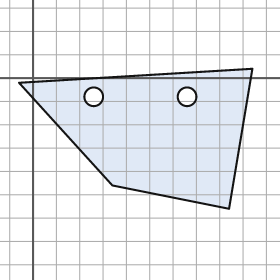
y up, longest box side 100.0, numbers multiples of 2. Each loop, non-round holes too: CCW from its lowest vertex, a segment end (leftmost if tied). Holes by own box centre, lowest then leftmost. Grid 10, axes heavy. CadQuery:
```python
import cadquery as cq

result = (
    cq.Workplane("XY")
    .moveTo(84.0, -56.0)
    .lineTo(94.0, 4.0)
    .lineTo(-6.0, -2.0)
    .lineTo(34.0, -46.0)
    .close()
    .moveTo(26.0, -8.0)
    .circle(4.0)
    .moveTo(66.0, -8.0)
    .circle(4.0)
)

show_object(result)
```